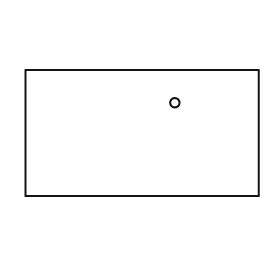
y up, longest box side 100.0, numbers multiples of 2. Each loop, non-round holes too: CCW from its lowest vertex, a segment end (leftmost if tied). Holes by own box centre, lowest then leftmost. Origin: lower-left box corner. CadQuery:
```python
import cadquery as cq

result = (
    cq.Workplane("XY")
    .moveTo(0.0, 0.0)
    .lineTo(100.0, 0.0)
    .lineTo(100.0, 54.0)
    .lineTo(0.0, 54.0)
    .close()
    .moveTo(64.0, 40.0)
    .circle(2.0)
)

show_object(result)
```